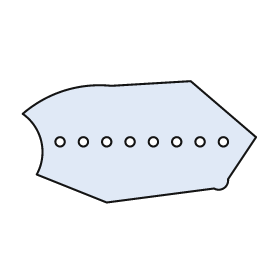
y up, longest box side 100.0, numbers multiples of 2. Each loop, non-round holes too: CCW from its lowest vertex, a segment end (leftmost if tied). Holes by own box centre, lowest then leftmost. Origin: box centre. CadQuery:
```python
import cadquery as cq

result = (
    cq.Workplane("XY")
    .moveTo(-14.0, -26.0)
    .lineTo(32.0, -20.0)
    .threePointArc((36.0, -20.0), (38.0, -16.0))
    .lineTo(50.0, 2.0)
    .lineTo(22.0, 26.0)
    .lineTo(-12.0, 24.0)
    .threePointArc((-32.0, 22.0), (-50.0, 12.0))
    .threePointArc((-42.0, 0.0), (-44.0, -14.0))
    .close()
    .moveTo(-34.0, 0.0)
    .circle(2.0)
    .moveTo(-24.0, 0.0)
    .circle(2.0)
    .moveTo(-14.0, 0.0)
    .circle(2.0)
    .moveTo(-4.0, 0.0)
    .circle(2.0)
    .moveTo(6.0, 0.0)
    .circle(2.0)
    .moveTo(16.0, 0.0)
    .circle(2.0)
    .moveTo(26.0, 0.0)
    .circle(2.0)
    .moveTo(36.0, 0.0)
    .circle(2.0)
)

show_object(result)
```